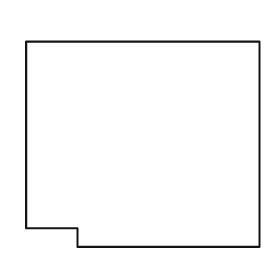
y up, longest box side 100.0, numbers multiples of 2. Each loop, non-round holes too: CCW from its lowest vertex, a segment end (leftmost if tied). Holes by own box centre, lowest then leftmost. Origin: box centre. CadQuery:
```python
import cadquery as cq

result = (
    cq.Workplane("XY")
    .moveTo(-28.0, -44.0)
    .lineTo(50.0, -44.0)
    .lineTo(50.0, 44.0)
    .lineTo(-50.0, 44.0)
    .lineTo(-50.0, -36.0)
    .lineTo(-28.0, -36.0)
    .close()
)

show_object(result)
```